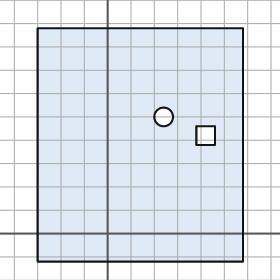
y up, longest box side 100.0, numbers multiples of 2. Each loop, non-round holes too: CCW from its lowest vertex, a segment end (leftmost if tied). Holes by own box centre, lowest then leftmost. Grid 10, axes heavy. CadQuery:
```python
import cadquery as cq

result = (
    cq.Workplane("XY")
    .moveTo(-30.0, -12.0)
    .lineTo(58.0, -12.0)
    .lineTo(58.0, 88.0)
    .lineTo(-30.0, 88.0)
    .close()
    .moveTo(38.0, 38.0)
    .lineTo(46.0, 38.0)
    .lineTo(46.0, 46.0)
    .lineTo(38.0, 46.0)
    .close()
    .moveTo(24.0, 50.0)
    .circle(4.0)
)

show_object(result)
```